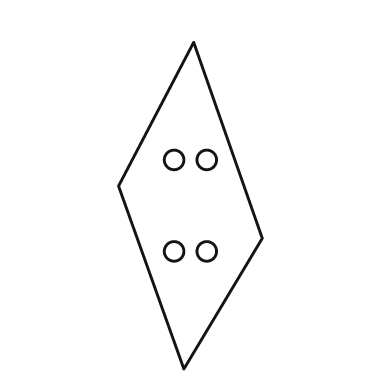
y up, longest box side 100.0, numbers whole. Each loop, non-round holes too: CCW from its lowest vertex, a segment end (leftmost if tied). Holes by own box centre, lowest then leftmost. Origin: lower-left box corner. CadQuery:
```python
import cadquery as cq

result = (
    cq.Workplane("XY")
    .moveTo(20.0, 0.0)
    .lineTo(44.0, 40.0)
    .lineTo(23.0, 100.0)
    .lineTo(0.0, 56.0)
    .close()
    .moveTo(17.0, 36.0)
    .circle(3.0)
    .moveTo(27.0, 36.0)
    .circle(3.0)
    .moveTo(17.0, 64.0)
    .circle(3.0)
    .moveTo(27.0, 64.0)
    .circle(3.0)
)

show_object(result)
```